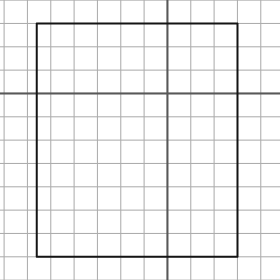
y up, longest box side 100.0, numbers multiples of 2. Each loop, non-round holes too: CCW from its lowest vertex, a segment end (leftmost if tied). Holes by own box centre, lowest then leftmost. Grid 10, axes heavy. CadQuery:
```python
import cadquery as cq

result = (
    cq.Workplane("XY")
    .moveTo(-56.0, -70.0)
    .lineTo(30.0, -70.0)
    .lineTo(30.0, 30.0)
    .lineTo(-56.0, 30.0)
    .close()
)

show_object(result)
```